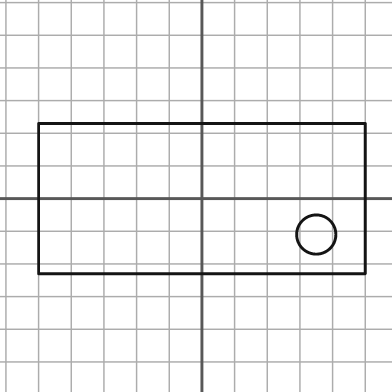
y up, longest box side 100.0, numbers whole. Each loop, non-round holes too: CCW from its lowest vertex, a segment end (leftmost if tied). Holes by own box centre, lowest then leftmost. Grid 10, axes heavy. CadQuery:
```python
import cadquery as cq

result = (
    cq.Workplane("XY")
    .moveTo(-50.0, -23.0)
    .lineTo(50.0, -23.0)
    .lineTo(50.0, 23.0)
    .lineTo(-50.0, 23.0)
    .close()
    .moveTo(35.0, -11.0)
    .circle(6.0)
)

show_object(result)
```